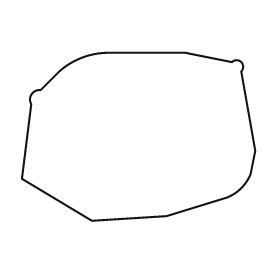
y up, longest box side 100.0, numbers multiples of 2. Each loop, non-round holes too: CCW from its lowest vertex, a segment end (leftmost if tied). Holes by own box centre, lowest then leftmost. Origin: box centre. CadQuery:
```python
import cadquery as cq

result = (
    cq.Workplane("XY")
    .moveTo(-20.0, -36.0)
    .lineTo(12.0, -34.0)
    .lineTo(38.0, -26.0)
    .threePointArc((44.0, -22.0), (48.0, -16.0))
    .lineTo(50.0, -6.0)
    .lineTo(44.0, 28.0)
    .threePointArc((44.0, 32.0), (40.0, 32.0))
    .lineTo(20.0, 36.0)
    .lineTo(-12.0, 36.0)
    .threePointArc((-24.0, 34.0), (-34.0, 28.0))
    .lineTo(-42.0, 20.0)
    .threePointArc((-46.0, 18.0), (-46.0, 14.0))
    .lineTo(-50.0, -18.0)
    .close()
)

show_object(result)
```